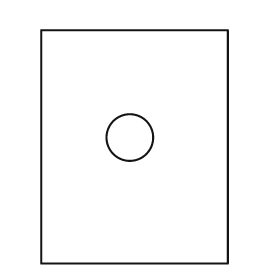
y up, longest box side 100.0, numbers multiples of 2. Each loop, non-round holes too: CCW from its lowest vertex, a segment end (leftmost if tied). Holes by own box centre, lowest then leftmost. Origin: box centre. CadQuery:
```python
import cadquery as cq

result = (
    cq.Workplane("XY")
    .moveTo(-40.0, -50.0)
    .lineTo(40.0, -50.0)
    .lineTo(40.0, 50.0)
    .lineTo(-40.0, 50.0)
    .close()
    .moveTo(-2.0, 4.0)
    .circle(10.0)
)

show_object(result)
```